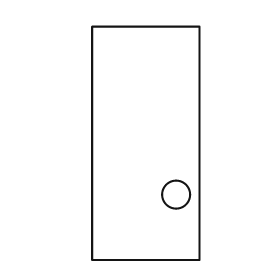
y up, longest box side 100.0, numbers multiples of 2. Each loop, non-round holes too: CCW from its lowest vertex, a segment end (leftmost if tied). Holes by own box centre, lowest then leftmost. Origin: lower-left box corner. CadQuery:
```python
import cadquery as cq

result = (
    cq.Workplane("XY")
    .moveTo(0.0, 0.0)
    .lineTo(46.0, 0.0)
    .lineTo(46.0, 100.0)
    .lineTo(0.0, 100.0)
    .close()
    .moveTo(36.0, 28.0)
    .circle(6.0)
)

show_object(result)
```